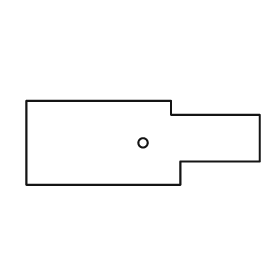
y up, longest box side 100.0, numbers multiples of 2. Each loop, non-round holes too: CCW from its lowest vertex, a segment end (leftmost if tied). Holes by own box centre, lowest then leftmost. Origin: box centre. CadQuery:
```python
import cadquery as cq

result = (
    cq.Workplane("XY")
    .moveTo(-50.0, -18.0)
    .lineTo(16.0, -18.0)
    .lineTo(16.0, -8.0)
    .lineTo(50.0, -8.0)
    .lineTo(50.0, 12.0)
    .lineTo(12.0, 12.0)
    .lineTo(12.0, 18.0)
    .lineTo(-50.0, 18.0)
    .close()
    .moveTo(0.0, 0.0)
    .circle(2.0)
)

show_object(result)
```